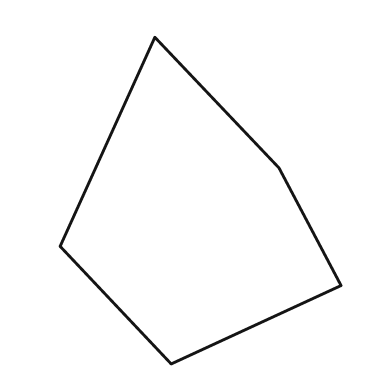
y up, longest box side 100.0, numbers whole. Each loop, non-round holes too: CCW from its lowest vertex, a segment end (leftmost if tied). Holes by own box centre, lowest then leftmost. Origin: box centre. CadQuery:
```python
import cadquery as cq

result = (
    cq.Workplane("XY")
    .moveTo(-9.0, -50.0)
    .lineTo(43.0, -26.0)
    .lineTo(24.0, 10.0)
    .lineTo(-14.0, 50.0)
    .lineTo(-43.0, -14.0)
    .close()
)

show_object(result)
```